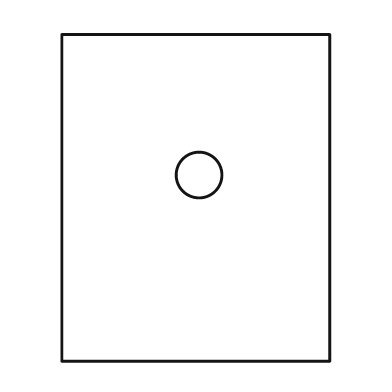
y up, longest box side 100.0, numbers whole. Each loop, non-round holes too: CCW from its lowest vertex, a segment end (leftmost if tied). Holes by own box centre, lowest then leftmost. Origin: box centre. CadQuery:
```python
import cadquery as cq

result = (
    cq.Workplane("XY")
    .moveTo(-41.0, -50.0)
    .lineTo(41.0, -50.0)
    .lineTo(41.0, 50.0)
    .lineTo(-41.0, 50.0)
    .close()
    .moveTo(1.0, 7.0)
    .circle(7.0)
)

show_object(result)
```